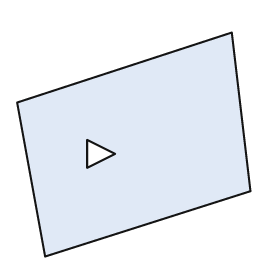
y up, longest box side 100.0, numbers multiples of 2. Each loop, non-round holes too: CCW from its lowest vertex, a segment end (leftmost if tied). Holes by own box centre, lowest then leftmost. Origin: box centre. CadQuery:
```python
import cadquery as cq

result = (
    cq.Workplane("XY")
    .moveTo(-38.0, -48.0)
    .lineTo(50.0, -20.0)
    .lineTo(42.0, 48.0)
    .lineTo(-50.0, 18.0)
    .close()
    .moveTo(-20.0, -10.0)
    .lineTo(-8.0, -4.0)
    .lineTo(-20.0, 2.0)
    .close()
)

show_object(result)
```